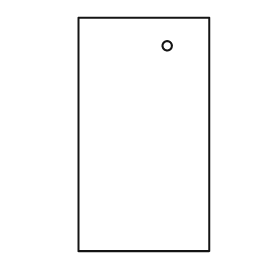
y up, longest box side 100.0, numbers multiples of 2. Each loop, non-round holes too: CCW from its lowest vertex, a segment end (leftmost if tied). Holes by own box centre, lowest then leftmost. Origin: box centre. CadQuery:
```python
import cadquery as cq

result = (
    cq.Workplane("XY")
    .moveTo(-28.0, -50.0)
    .lineTo(28.0, -50.0)
    .lineTo(28.0, 50.0)
    .lineTo(-28.0, 50.0)
    .close()
    .moveTo(10.0, 38.0)
    .circle(2.0)
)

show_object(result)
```